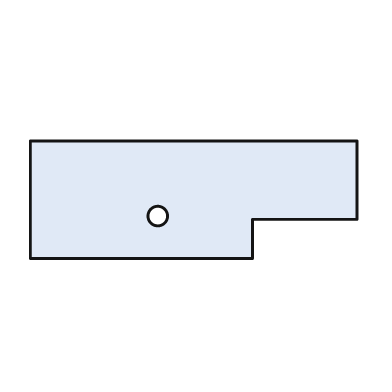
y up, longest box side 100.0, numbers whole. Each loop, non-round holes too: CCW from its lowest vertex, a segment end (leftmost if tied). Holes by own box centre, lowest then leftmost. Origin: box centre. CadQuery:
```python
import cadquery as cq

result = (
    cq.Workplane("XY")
    .moveTo(-50.0, -18.0)
    .lineTo(18.0, -18.0)
    .lineTo(18.0, -6.0)
    .lineTo(50.0, -6.0)
    .lineTo(50.0, 18.0)
    .lineTo(-50.0, 18.0)
    .close()
    .moveTo(-11.0, -5.0)
    .circle(3.0)
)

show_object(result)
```